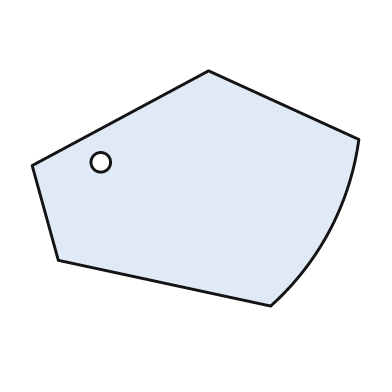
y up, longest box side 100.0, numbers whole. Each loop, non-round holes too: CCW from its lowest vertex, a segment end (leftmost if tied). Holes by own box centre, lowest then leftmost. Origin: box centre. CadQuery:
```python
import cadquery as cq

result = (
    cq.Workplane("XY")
    .moveTo(23.0, -36.0)
    .threePointArc((41.0, -13.0), (50.0, 15.0))
    .lineTo(4.0, 36.0)
    .lineTo(-50.0, 7.0)
    .lineTo(-42.0, -22.0)
    .close()
    .moveTo(-29.0, 8.0)
    .circle(3.0)
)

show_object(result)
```